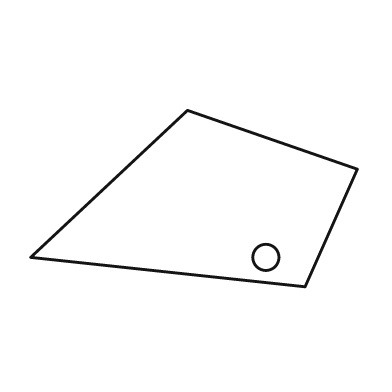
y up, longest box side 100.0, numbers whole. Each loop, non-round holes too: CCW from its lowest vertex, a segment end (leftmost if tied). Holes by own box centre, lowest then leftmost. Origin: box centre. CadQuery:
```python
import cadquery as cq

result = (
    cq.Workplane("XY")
    .moveTo(34.0, -27.0)
    .lineTo(50.0, 9.0)
    .lineTo(-2.0, 27.0)
    .lineTo(-50.0, -18.0)
    .close()
    .moveTo(22.0, -18.0)
    .circle(4.0)
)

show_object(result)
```